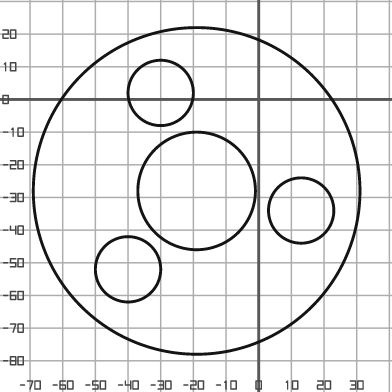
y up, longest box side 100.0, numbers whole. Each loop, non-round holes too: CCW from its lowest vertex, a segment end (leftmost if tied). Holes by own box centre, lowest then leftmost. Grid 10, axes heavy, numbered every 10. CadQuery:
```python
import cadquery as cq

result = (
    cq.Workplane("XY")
    .moveTo(-19.0, -28.0)
    .circle(50.0)
    .moveTo(-40.0, -52.0)
    .circle(10.0)
    .moveTo(13.0, -34.0)
    .circle(10.0)
    .moveTo(-19.0, -28.0)
    .circle(18.0)
    .moveTo(-30.0, 2.0)
    .circle(10.0)
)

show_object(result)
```